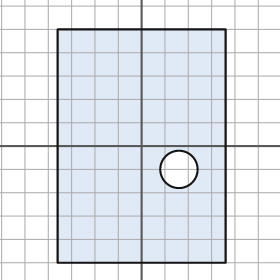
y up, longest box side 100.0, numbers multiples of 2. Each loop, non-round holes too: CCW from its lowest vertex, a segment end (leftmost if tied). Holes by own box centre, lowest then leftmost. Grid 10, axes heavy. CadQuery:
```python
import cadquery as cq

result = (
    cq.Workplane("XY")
    .moveTo(-36.0, -50.0)
    .lineTo(36.0, -50.0)
    .lineTo(36.0, 50.0)
    .lineTo(-36.0, 50.0)
    .close()
    .moveTo(16.0, -10.0)
    .circle(8.0)
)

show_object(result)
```